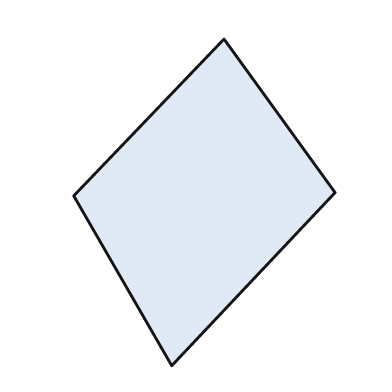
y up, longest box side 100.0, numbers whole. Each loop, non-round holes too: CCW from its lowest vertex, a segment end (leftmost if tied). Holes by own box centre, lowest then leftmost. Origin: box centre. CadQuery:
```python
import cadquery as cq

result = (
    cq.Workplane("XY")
    .moveTo(-10.0, -50.0)
    .lineTo(40.0, 3.0)
    .lineTo(6.0, 50.0)
    .lineTo(-40.0, 2.0)
    .close()
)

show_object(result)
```